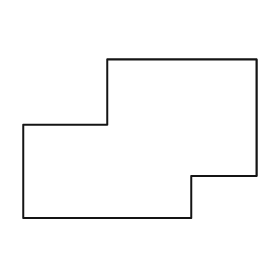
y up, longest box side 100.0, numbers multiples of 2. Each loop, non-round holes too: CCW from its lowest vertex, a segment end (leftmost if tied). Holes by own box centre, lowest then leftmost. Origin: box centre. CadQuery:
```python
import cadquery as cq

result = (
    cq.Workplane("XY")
    .moveTo(-50.0, -34.0)
    .lineTo(22.0, -34.0)
    .lineTo(22.0, -16.0)
    .lineTo(50.0, -16.0)
    .lineTo(50.0, 34.0)
    .lineTo(-14.0, 34.0)
    .lineTo(-14.0, 6.0)
    .lineTo(-50.0, 6.0)
    .close()
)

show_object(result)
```